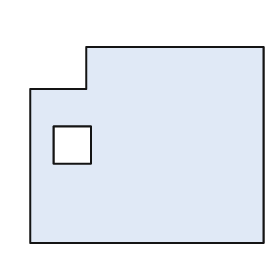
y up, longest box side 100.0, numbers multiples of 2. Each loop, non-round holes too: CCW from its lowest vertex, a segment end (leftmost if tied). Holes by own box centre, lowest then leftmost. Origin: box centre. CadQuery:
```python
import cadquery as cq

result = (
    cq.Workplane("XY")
    .moveTo(-50.0, -42.0)
    .lineTo(50.0, -42.0)
    .lineTo(50.0, 42.0)
    .lineTo(-26.0, 42.0)
    .lineTo(-26.0, 24.0)
    .lineTo(-50.0, 24.0)
    .close()
    .moveTo(-40.0, -8.0)
    .lineTo(-24.0, -8.0)
    .lineTo(-24.0, 8.0)
    .lineTo(-40.0, 8.0)
    .close()
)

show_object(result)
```